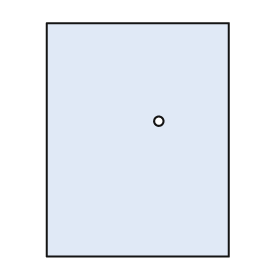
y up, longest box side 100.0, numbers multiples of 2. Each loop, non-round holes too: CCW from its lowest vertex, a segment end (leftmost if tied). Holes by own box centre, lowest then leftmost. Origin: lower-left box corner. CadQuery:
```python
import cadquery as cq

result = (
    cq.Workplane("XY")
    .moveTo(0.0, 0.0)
    .lineTo(78.0, 0.0)
    .lineTo(78.0, 100.0)
    .lineTo(0.0, 100.0)
    .close()
    .moveTo(48.0, 58.0)
    .circle(2.0)
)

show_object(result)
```